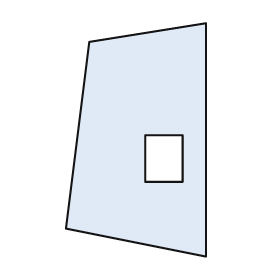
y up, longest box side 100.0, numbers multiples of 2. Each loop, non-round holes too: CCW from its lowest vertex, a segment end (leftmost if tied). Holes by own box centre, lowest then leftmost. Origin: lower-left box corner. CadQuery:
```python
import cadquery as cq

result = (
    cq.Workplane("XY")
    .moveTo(60.0, 0.0)
    .lineTo(60.0, 100.0)
    .lineTo(10.0, 92.0)
    .lineTo(0.0, 12.0)
    .close()
    .moveTo(34.0, 32.0)
    .lineTo(50.0, 32.0)
    .lineTo(50.0, 52.0)
    .lineTo(34.0, 52.0)
    .close()
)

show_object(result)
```